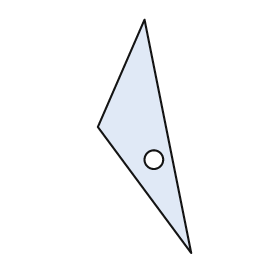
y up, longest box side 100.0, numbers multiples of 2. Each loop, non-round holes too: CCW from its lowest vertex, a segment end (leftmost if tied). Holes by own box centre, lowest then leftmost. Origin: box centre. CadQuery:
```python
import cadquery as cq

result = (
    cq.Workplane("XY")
    .moveTo(20.0, -50.0)
    .lineTo(0.0, 50.0)
    .lineTo(-20.0, 4.0)
    .close()
    .moveTo(4.0, -10.0)
    .circle(4.0)
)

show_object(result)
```